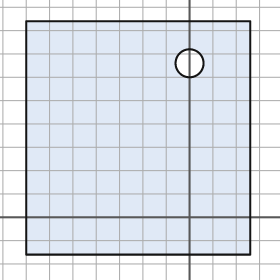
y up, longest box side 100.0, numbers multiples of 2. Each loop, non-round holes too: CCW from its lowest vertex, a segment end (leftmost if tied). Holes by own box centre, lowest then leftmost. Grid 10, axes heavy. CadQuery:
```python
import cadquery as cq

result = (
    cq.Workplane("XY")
    .moveTo(-70.0, -16.0)
    .lineTo(26.0, -16.0)
    .lineTo(26.0, 84.0)
    .lineTo(-70.0, 84.0)
    .close()
    .moveTo(0.0, 66.0)
    .circle(6.0)
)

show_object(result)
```